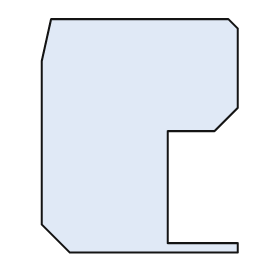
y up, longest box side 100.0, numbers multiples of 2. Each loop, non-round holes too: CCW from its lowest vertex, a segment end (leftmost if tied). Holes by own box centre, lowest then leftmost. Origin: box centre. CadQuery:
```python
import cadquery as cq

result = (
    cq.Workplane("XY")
    .moveTo(-30.0, -50.0)
    .lineTo(42.0, -50.0)
    .lineTo(42.0, -46.0)
    .lineTo(12.0, -46.0)
    .lineTo(12.0, 2.0)
    .lineTo(32.0, 2.0)
    .lineTo(42.0, 12.0)
    .lineTo(42.0, 46.0)
    .lineTo(38.0, 50.0)
    .lineTo(-38.0, 50.0)
    .lineTo(-42.0, 32.0)
    .lineTo(-42.0, -38.0)
    .close()
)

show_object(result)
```